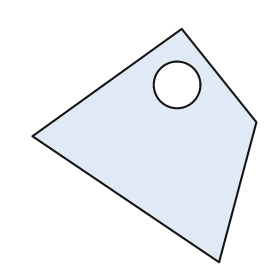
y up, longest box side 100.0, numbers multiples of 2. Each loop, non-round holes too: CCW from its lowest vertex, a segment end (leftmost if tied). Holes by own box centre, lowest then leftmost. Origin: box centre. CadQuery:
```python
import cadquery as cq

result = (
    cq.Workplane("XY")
    .moveTo(32.0, -50.0)
    .lineTo(48.0, 10.0)
    .lineTo(16.0, 50.0)
    .lineTo(-48.0, 4.0)
    .close()
    .moveTo(14.0, 26.0)
    .circle(10.0)
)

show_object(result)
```